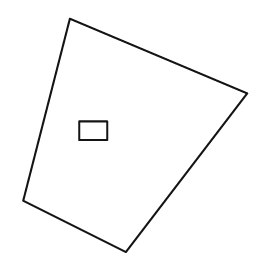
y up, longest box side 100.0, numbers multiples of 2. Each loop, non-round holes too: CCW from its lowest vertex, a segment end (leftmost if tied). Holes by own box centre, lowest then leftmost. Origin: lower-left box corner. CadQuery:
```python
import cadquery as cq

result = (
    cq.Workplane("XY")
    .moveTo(44.0, 0.0)
    .lineTo(96.0, 68.0)
    .lineTo(20.0, 100.0)
    .lineTo(0.0, 22.0)
    .close()
    .moveTo(24.0, 48.0)
    .lineTo(36.0, 48.0)
    .lineTo(36.0, 56.0)
    .lineTo(24.0, 56.0)
    .close()
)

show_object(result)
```